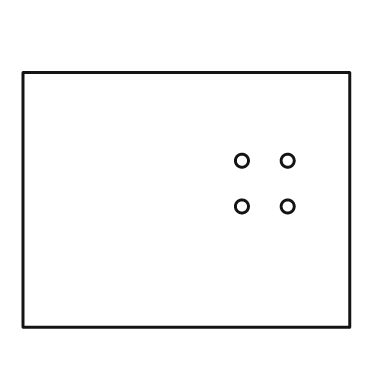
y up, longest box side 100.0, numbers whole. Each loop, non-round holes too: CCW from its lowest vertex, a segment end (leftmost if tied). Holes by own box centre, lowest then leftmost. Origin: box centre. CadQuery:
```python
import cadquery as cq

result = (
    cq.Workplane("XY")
    .moveTo(-50.0, -39.0)
    .lineTo(50.0, -39.0)
    .lineTo(50.0, 39.0)
    .lineTo(-50.0, 39.0)
    .close()
    .moveTo(17.0, -2.0)
    .circle(2.0)
    .moveTo(31.0, -2.0)
    .circle(2.0)
    .moveTo(17.0, 12.0)
    .circle(2.0)
    .moveTo(31.0, 12.0)
    .circle(2.0)
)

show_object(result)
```